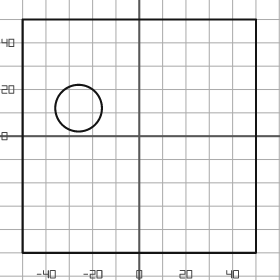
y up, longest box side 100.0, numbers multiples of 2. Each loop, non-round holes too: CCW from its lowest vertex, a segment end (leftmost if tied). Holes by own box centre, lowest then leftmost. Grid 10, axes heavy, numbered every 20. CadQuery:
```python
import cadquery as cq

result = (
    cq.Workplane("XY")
    .moveTo(-50.0, -50.0)
    .lineTo(50.0, -50.0)
    .lineTo(50.0, 50.0)
    .lineTo(-50.0, 50.0)
    .close()
    .moveTo(-26.0, 12.0)
    .circle(10.0)
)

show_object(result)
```